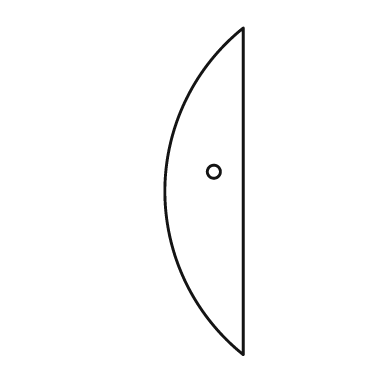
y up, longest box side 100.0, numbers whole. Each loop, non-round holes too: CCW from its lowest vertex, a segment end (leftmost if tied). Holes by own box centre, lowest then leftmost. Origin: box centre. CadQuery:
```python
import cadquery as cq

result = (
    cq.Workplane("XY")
    .moveTo(12.0, -50.0)
    .lineTo(12.0, 50.0)
    .threePointArc((-12.0, 0.0), (12.0, -50.0))
    .close()
    .moveTo(3.0, 6.0)
    .circle(2.0)
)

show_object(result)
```